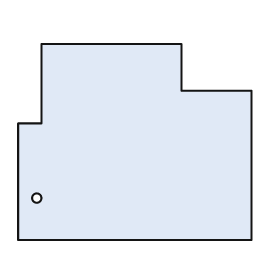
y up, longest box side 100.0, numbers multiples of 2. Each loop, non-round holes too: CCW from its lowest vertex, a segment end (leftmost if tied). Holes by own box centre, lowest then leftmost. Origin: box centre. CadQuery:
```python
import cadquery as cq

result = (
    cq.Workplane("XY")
    .moveTo(-50.0, -42.0)
    .lineTo(50.0, -42.0)
    .lineTo(50.0, 22.0)
    .lineTo(20.0, 22.0)
    .lineTo(20.0, 42.0)
    .lineTo(-40.0, 42.0)
    .lineTo(-40.0, 8.0)
    .lineTo(-50.0, 8.0)
    .close()
    .moveTo(-42.0, -24.0)
    .circle(2.0)
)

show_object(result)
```